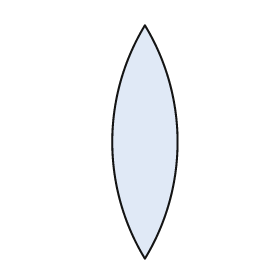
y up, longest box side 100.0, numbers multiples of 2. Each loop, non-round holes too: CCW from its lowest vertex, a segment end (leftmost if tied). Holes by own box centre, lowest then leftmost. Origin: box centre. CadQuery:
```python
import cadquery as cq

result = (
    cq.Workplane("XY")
    .moveTo(0.0, -50.0)
    .threePointArc((14.0, 0.0), (0.0, 50.0))
    .threePointArc((-14.0, 0.0), (0.0, -50.0))
    .close()
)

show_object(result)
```